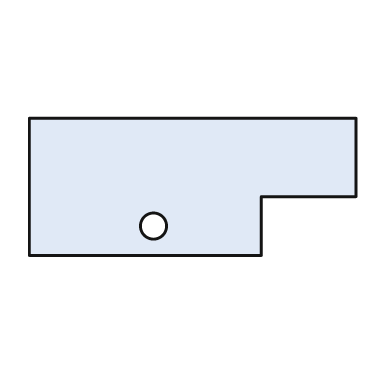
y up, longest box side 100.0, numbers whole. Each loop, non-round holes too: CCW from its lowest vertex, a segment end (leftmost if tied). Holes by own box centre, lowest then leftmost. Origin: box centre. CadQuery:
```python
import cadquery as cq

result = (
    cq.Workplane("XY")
    .moveTo(-50.0, -21.0)
    .lineTo(21.0, -21.0)
    .lineTo(21.0, -3.0)
    .lineTo(50.0, -3.0)
    .lineTo(50.0, 21.0)
    .lineTo(-50.0, 21.0)
    .close()
    .moveTo(-12.0, -12.0)
    .circle(4.0)
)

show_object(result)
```